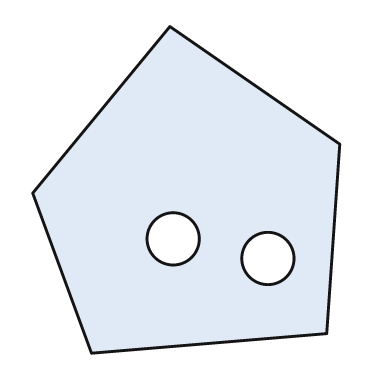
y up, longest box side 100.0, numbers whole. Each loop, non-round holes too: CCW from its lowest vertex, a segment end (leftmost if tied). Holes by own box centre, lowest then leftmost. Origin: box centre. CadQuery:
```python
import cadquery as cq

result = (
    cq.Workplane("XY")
    .moveTo(-29.0, -50.0)
    .lineTo(43.0, -44.0)
    .lineTo(47.0, 14.0)
    .lineTo(-5.0, 50.0)
    .lineTo(-47.0, -1.0)
    .close()
    .moveTo(25.0, -21.0)
    .circle(8.0)
    .moveTo(-4.0, -15.0)
    .circle(8.0)
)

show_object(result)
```